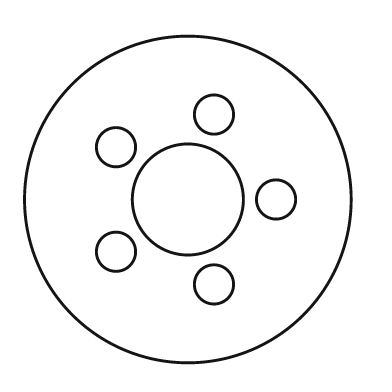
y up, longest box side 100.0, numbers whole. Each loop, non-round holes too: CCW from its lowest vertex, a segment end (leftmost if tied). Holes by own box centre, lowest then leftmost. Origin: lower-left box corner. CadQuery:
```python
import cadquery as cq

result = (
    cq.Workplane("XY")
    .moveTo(50.0, 50.0)
    .circle(50.0)
    .moveTo(58.0, 24.0)
    .circle(6.0)
    .moveTo(28.0, 34.0)
    .circle(6.0)
    .moveTo(50.0, 50.0)
    .circle(17.0)
    .moveTo(77.0, 50.0)
    .circle(6.0)
    .moveTo(28.0, 66.0)
    .circle(6.0)
    .moveTo(58.0, 76.0)
    .circle(6.0)
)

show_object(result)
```